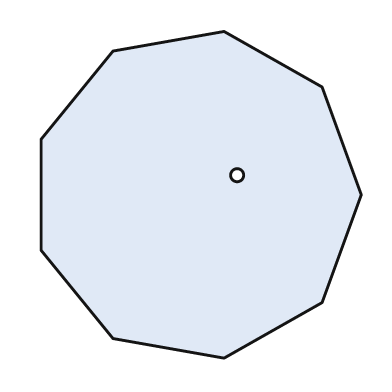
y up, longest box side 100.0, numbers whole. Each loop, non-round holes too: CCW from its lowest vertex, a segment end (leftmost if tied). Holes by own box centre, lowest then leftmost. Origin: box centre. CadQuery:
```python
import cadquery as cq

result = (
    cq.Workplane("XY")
    .moveTo(7.0, -50.0)
    .lineTo(37.0, -33.0)
    .lineTo(49.0, 0.0)
    .lineTo(37.0, 33.0)
    .lineTo(7.0, 50.0)
    .lineTo(-27.0, 44.0)
    .lineTo(-49.0, 17.0)
    .lineTo(-49.0, -17.0)
    .lineTo(-27.0, -44.0)
    .close()
    .moveTo(11.0, 6.0)
    .circle(2.0)
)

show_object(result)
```